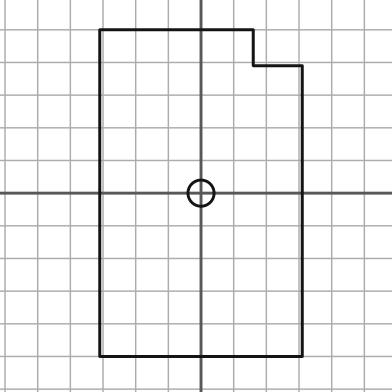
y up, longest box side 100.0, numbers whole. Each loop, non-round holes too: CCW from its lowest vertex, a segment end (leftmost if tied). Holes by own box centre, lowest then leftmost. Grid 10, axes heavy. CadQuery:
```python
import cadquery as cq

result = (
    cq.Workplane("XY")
    .moveTo(-31.0, -50.0)
    .lineTo(31.0, -50.0)
    .lineTo(31.0, 39.0)
    .lineTo(16.0, 39.0)
    .lineTo(16.0, 50.0)
    .lineTo(-31.0, 50.0)
    .close()
    .moveTo(0.0, 0.0)
    .circle(4.0)
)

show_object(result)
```